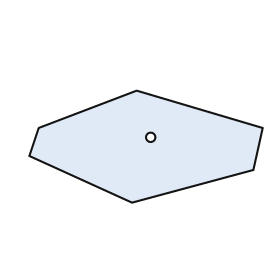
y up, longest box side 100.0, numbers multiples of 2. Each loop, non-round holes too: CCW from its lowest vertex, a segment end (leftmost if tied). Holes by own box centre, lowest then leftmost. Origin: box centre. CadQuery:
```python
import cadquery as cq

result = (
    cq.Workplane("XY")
    .moveTo(-6.0, -24.0)
    .lineTo(46.0, -10.0)
    .lineTo(50.0, 8.0)
    .lineTo(-4.0, 24.0)
    .lineTo(-46.0, 8.0)
    .lineTo(-50.0, -4.0)
    .close()
    .moveTo(2.0, 4.0)
    .circle(2.0)
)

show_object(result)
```